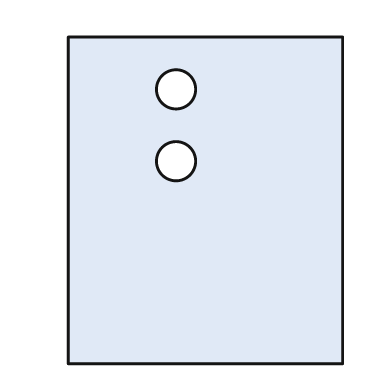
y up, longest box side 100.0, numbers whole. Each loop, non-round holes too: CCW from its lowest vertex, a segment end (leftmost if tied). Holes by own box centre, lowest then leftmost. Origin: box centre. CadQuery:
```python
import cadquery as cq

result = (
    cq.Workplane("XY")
    .moveTo(-42.0, -50.0)
    .lineTo(42.0, -50.0)
    .lineTo(42.0, 50.0)
    .lineTo(-42.0, 50.0)
    .close()
    .moveTo(-9.0, 12.0)
    .circle(6.0)
    .moveTo(-9.0, 34.0)
    .circle(6.0)
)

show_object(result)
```